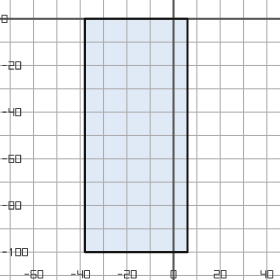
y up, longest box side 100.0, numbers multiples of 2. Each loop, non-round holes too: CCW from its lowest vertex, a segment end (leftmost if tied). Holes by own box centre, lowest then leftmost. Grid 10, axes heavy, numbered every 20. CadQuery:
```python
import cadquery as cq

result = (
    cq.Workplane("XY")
    .moveTo(-38.0, -100.0)
    .lineTo(6.0, -100.0)
    .lineTo(6.0, 0.0)
    .lineTo(-38.0, 0.0)
    .close()
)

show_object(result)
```